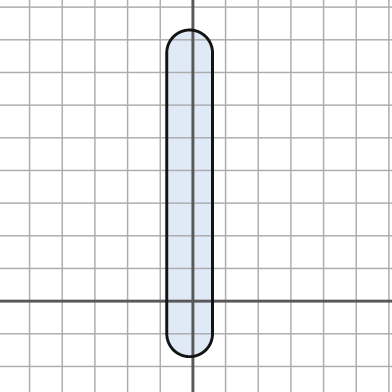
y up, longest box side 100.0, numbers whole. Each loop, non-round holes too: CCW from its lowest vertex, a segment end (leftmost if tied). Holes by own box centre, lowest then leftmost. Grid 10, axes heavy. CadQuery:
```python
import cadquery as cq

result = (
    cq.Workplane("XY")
    .moveTo(-8.0, -10.0)
    .threePointArc((-1.0, -17.0), (6.0, -10.0))
    .lineTo(6.0, 76.0)
    .threePointArc((-1.0, 83.0), (-8.0, 76.0))
    .close()
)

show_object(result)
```